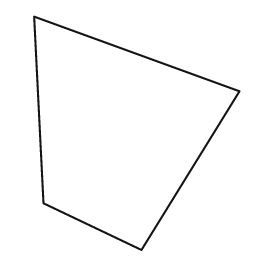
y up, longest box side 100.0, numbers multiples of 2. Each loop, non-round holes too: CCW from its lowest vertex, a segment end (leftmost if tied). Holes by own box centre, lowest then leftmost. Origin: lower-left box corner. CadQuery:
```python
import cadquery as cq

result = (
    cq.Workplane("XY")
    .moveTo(46.0, 0.0)
    .lineTo(88.0, 68.0)
    .lineTo(0.0, 100.0)
    .lineTo(4.0, 20.0)
    .close()
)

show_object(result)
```